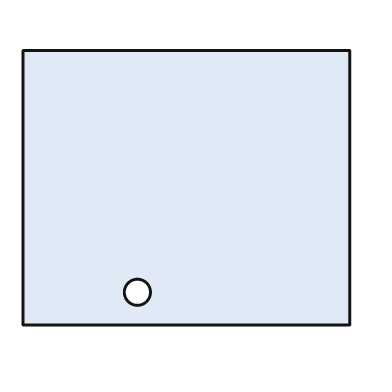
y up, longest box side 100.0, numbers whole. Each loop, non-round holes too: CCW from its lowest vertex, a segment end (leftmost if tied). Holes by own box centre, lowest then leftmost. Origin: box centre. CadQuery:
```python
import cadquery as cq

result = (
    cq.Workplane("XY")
    .moveTo(-50.0, -42.0)
    .lineTo(50.0, -42.0)
    .lineTo(50.0, 42.0)
    .lineTo(-50.0, 42.0)
    .close()
    .moveTo(-15.0, -32.0)
    .circle(4.0)
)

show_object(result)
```